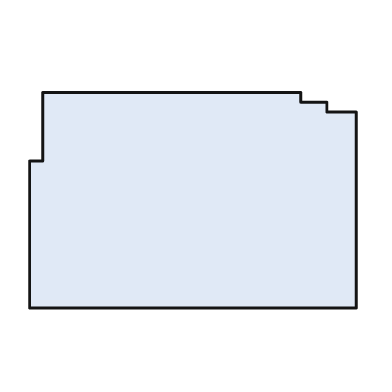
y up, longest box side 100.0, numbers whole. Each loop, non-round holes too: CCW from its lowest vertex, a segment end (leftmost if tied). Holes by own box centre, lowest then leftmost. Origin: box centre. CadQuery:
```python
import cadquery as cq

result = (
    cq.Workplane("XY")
    .moveTo(-50.0, -33.0)
    .lineTo(50.0, -33.0)
    .lineTo(50.0, 27.0)
    .lineTo(41.0, 27.0)
    .lineTo(41.0, 30.0)
    .lineTo(33.0, 30.0)
    .lineTo(33.0, 33.0)
    .lineTo(-46.0, 33.0)
    .lineTo(-46.0, 12.0)
    .lineTo(-50.0, 12.0)
    .close()
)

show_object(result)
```